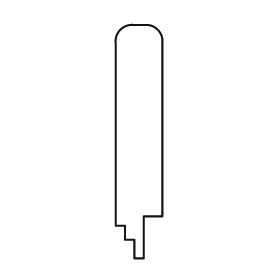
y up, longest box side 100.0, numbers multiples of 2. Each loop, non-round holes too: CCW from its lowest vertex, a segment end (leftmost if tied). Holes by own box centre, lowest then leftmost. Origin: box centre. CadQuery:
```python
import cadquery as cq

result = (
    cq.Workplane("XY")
    .moveTo(-2.0, -50.0)
    .lineTo(2.0, -50.0)
    .lineTo(2.0, -32.0)
    .lineTo(10.0, -32.0)
    .lineTo(10.0, 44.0)
    .threePointArc((8.0, 48.0), (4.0, 50.0))
    .lineTo(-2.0, 50.0)
    .threePointArc((-8.0, 48.0), (-10.0, 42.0))
    .lineTo(-10.0, -36.0)
    .lineTo(-6.0, -36.0)
    .lineTo(-6.0, -42.0)
    .lineTo(-2.0, -42.0)
    .close()
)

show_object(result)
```